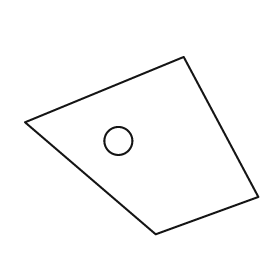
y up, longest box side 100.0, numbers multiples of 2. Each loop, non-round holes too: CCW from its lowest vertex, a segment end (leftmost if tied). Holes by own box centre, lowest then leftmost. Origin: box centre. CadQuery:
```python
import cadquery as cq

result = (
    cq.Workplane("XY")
    .moveTo(6.0, -38.0)
    .lineTo(50.0, -22.0)
    .lineTo(18.0, 38.0)
    .lineTo(-50.0, 10.0)
    .close()
    .moveTo(-10.0, 2.0)
    .circle(6.0)
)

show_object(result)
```